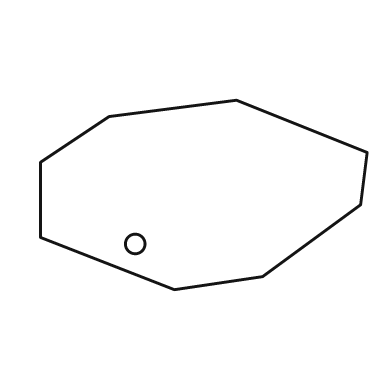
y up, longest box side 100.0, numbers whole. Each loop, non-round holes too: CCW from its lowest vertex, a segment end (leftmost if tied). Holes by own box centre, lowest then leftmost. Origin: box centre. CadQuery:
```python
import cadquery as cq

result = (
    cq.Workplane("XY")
    .moveTo(-9.0, -29.0)
    .lineTo(18.0, -25.0)
    .lineTo(48.0, -3.0)
    .lineTo(50.0, 13.0)
    .lineTo(10.0, 29.0)
    .lineTo(-29.0, 24.0)
    .lineTo(-50.0, 10.0)
    .lineTo(-50.0, -13.0)
    .close()
    .moveTo(-21.0, -15.0)
    .circle(3.0)
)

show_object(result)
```